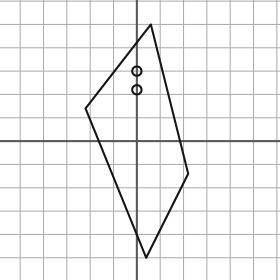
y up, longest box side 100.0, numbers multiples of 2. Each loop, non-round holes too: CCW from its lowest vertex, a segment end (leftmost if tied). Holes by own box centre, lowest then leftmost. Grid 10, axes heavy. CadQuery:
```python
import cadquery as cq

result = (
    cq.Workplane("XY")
    .moveTo(4.0, -50.0)
    .lineTo(22.0, -14.0)
    .lineTo(6.0, 50.0)
    .lineTo(-22.0, 14.0)
    .close()
    .moveTo(0.0, 22.0)
    .circle(2.0)
    .moveTo(0.0, 30.0)
    .circle(2.0)
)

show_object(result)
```